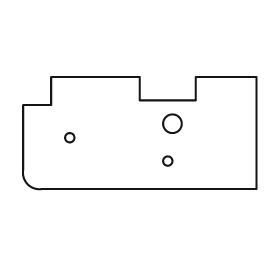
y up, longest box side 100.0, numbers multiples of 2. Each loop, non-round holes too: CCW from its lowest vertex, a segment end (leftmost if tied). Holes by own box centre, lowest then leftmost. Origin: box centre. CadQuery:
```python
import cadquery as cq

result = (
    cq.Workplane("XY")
    .moveTo(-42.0, -24.0)
    .lineTo(50.0, -24.0)
    .lineTo(50.0, 24.0)
    .lineTo(24.0, 24.0)
    .lineTo(24.0, 14.0)
    .lineTo(0.0, 14.0)
    .lineTo(0.0, 24.0)
    .lineTo(-38.0, 24.0)
    .lineTo(-38.0, 12.0)
    .lineTo(-50.0, 12.0)
    .lineTo(-50.0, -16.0)
    .threePointArc((-48.0, -22.0), (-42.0, -24.0))
    .close()
    .moveTo(12.0, -12.0)
    .circle(2.0)
    .moveTo(-30.0, -2.0)
    .circle(2.0)
    .moveTo(14.0, 4.0)
    .circle(4.0)
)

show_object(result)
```